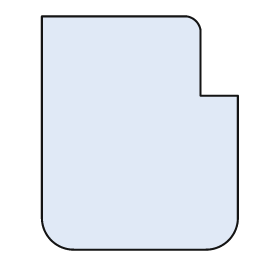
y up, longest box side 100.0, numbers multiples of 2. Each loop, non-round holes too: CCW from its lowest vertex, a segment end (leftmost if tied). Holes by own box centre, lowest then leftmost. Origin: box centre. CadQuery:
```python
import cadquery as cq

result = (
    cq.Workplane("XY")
    .moveTo(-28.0, -50.0)
    .lineTo(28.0, -50.0)
    .threePointArc((38.0, -46.0), (42.0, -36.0))
    .lineTo(42.0, 16.0)
    .lineTo(26.0, 16.0)
    .lineTo(26.0, 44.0)
    .threePointArc((24.0, 48.0), (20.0, 50.0))
    .lineTo(-42.0, 50.0)
    .lineTo(-42.0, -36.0)
    .threePointArc((-38.0, -46.0), (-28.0, -50.0))
    .close()
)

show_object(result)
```